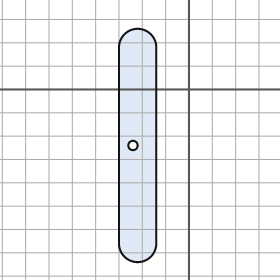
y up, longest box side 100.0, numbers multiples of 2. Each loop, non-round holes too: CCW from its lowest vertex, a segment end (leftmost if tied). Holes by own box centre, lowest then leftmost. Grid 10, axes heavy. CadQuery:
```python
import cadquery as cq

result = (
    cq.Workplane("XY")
    .moveTo(-30.0, -66.0)
    .threePointArc((-22.0, -74.0), (-14.0, -66.0))
    .lineTo(-14.0, 18.0)
    .threePointArc((-22.0, 26.0), (-30.0, 18.0))
    .close()
    .moveTo(-24.0, -24.0)
    .circle(2.0)
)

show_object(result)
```